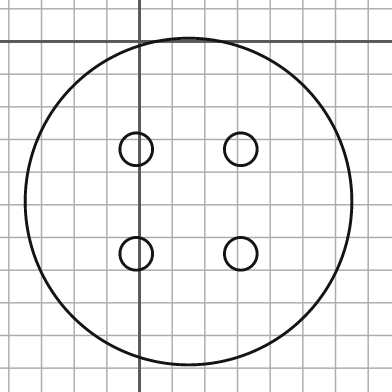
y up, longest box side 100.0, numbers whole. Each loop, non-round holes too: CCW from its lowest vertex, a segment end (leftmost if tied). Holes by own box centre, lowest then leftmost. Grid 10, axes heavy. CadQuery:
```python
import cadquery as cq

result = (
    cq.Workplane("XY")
    .moveTo(15.0, -49.0)
    .circle(50.0)
    .moveTo(-1.0, -65.0)
    .circle(5.0)
    .moveTo(31.0, -65.0)
    .circle(5.0)
    .moveTo(-1.0, -33.0)
    .circle(5.0)
    .moveTo(31.0, -33.0)
    .circle(5.0)
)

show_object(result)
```